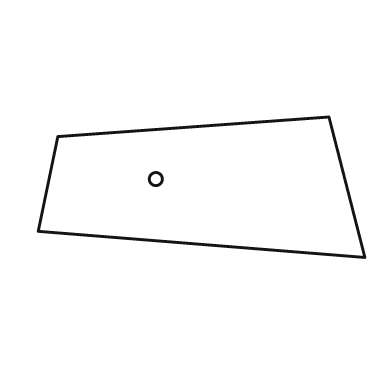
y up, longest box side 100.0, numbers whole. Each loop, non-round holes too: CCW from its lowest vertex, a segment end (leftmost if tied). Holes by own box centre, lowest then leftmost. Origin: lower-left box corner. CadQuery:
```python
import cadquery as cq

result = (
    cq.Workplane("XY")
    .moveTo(100.0, 0.0)
    .lineTo(89.0, 43.0)
    .lineTo(6.0, 37.0)
    .lineTo(0.0, 8.0)
    .close()
    .moveTo(36.0, 24.0)
    .circle(2.0)
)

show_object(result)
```